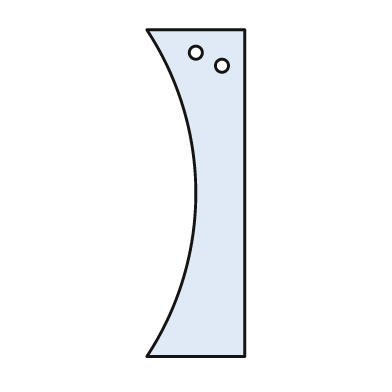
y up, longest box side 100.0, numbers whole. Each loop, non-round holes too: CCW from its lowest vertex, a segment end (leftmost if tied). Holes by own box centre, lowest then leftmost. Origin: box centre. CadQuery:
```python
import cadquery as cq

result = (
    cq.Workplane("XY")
    .moveTo(-15.0, -50.0)
    .lineTo(15.0, -50.0)
    .lineTo(15.0, 50.0)
    .lineTo(-15.0, 50.0)
    .threePointArc((0.0, 0.0), (-15.0, -50.0))
    .close()
    .moveTo(8.0, 39.0)
    .circle(2.0)
    .moveTo(0.0, 43.0)
    .circle(2.0)
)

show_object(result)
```